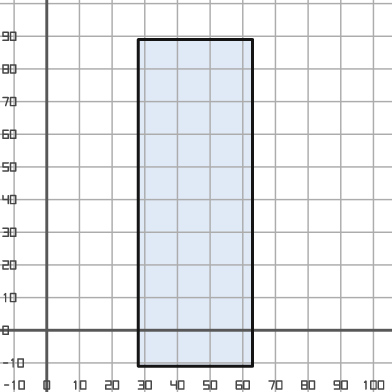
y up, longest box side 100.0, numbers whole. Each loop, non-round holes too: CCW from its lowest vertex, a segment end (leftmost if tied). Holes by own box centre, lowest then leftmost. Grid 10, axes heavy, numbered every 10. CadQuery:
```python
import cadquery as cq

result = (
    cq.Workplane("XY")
    .moveTo(28.0, -11.0)
    .lineTo(63.0, -11.0)
    .lineTo(63.0, 89.0)
    .lineTo(28.0, 89.0)
    .close()
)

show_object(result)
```